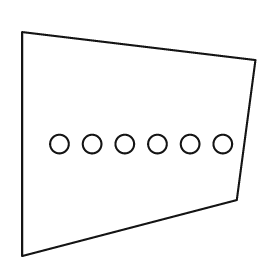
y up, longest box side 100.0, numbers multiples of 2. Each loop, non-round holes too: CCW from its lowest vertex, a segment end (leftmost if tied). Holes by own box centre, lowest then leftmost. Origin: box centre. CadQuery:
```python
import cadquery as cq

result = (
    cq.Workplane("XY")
    .moveTo(-50.0, -48.0)
    .lineTo(42.0, -24.0)
    .lineTo(50.0, 36.0)
    .lineTo(-50.0, 48.0)
    .close()
    .moveTo(-34.0, 0.0)
    .circle(4.0)
    .moveTo(-20.0, 0.0)
    .circle(4.0)
    .moveTo(-6.0, 0.0)
    .circle(4.0)
    .moveTo(8.0, 0.0)
    .circle(4.0)
    .moveTo(22.0, 0.0)
    .circle(4.0)
    .moveTo(36.0, 0.0)
    .circle(4.0)
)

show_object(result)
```